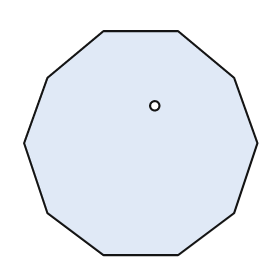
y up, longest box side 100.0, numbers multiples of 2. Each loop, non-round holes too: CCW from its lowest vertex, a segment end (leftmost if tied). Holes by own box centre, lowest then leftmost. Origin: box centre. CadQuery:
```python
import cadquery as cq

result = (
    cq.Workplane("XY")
    .moveTo(-16.0, -48.0)
    .lineTo(16.0, -48.0)
    .lineTo(40.0, -30.0)
    .lineTo(50.0, 0.0)
    .lineTo(40.0, 28.0)
    .lineTo(16.0, 48.0)
    .lineTo(-16.0, 48.0)
    .lineTo(-40.0, 28.0)
    .lineTo(-50.0, 0.0)
    .lineTo(-40.0, -30.0)
    .close()
    .moveTo(6.0, 16.0)
    .circle(2.0)
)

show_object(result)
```